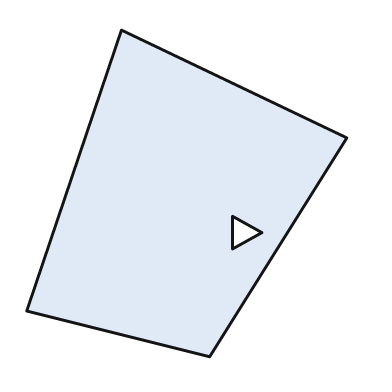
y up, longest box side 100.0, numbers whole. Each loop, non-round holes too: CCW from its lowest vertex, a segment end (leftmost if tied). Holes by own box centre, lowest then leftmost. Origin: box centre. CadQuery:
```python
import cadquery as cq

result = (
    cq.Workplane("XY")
    .moveTo(7.0, -50.0)
    .lineTo(49.0, 17.0)
    .lineTo(-20.0, 50.0)
    .lineTo(-49.0, -36.0)
    .close()
    .moveTo(14.0, -17.0)
    .lineTo(23.0, -12.0)
    .lineTo(14.0, -7.0)
    .close()
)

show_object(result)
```